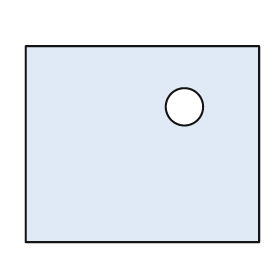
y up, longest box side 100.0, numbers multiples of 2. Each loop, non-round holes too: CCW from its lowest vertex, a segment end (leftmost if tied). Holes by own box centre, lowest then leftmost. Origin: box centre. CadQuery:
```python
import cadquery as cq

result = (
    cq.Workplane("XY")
    .moveTo(-50.0, -42.0)
    .lineTo(50.0, -42.0)
    .lineTo(50.0, 42.0)
    .lineTo(-50.0, 42.0)
    .close()
    .moveTo(18.0, 16.0)
    .circle(8.0)
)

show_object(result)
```